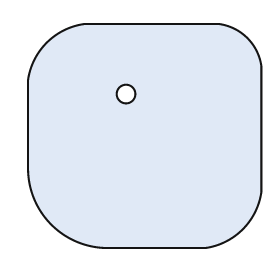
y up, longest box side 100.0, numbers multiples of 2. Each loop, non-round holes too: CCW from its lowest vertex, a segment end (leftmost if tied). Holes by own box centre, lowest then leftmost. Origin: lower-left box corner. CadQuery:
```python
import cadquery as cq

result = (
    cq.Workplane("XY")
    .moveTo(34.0, 0.0)
    .lineTo(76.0, 0.0)
    .threePointArc((92.0, 8.0), (100.0, 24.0))
    .lineTo(100.0, 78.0)
    .threePointArc((94.0, 90.0), (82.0, 96.0))
    .lineTo(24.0, 96.0)
    .threePointArc((8.0, 88.0), (0.0, 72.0))
    .lineTo(0.0, 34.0)
    .threePointArc((10.0, 10.0), (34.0, 0.0))
    .close()
    .moveTo(42.0, 66.0)
    .circle(4.0)
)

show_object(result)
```